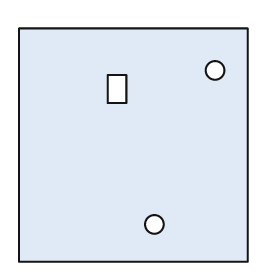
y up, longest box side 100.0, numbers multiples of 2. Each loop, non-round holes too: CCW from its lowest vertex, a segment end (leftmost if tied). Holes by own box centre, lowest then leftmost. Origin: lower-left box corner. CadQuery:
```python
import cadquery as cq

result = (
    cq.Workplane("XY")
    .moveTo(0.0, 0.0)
    .lineTo(98.0, 0.0)
    .lineTo(98.0, 100.0)
    .lineTo(0.0, 100.0)
    .close()
    .moveTo(58.0, 16.0)
    .circle(4.0)
    .moveTo(38.0, 68.0)
    .lineTo(46.0, 68.0)
    .lineTo(46.0, 80.0)
    .lineTo(38.0, 80.0)
    .close()
    .moveTo(84.0, 82.0)
    .circle(4.0)
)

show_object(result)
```